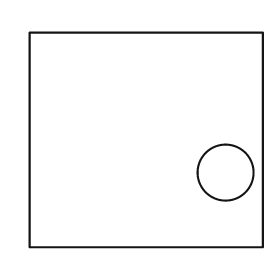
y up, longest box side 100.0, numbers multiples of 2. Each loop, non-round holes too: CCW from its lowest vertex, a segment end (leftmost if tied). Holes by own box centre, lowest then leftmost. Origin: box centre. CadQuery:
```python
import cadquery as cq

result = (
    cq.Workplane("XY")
    .moveTo(-50.0, -46.0)
    .lineTo(50.0, -46.0)
    .lineTo(50.0, 46.0)
    .lineTo(-50.0, 46.0)
    .close()
    .moveTo(34.0, -14.0)
    .circle(12.0)
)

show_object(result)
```